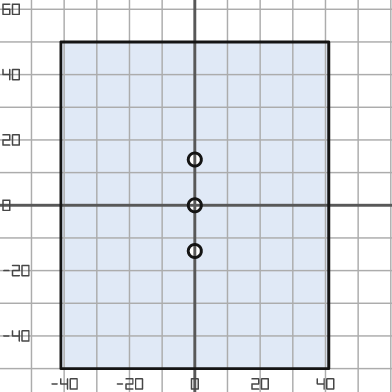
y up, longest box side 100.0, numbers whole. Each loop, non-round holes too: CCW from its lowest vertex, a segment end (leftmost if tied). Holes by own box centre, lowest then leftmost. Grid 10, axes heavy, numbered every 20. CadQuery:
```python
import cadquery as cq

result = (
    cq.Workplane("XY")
    .moveTo(-41.0, -50.0)
    .lineTo(41.0, -50.0)
    .lineTo(41.0, 50.0)
    .lineTo(-41.0, 50.0)
    .close()
    .moveTo(0.0, -14.0)
    .circle(2.0)
    .moveTo(0.0, 0.0)
    .circle(2.0)
    .moveTo(0.0, 14.0)
    .circle(2.0)
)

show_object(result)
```